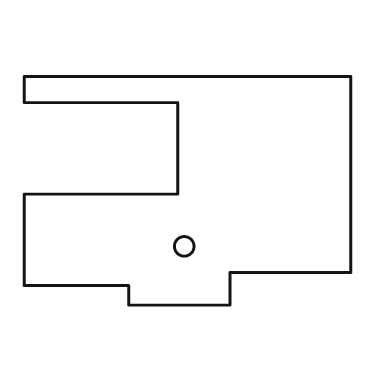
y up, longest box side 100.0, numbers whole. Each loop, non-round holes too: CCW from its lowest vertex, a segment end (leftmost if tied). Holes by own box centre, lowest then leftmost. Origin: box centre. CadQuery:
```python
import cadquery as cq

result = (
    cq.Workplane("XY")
    .moveTo(-18.0, -35.0)
    .lineTo(13.0, -35.0)
    .lineTo(13.0, -25.0)
    .lineTo(50.0, -25.0)
    .lineTo(50.0, 35.0)
    .lineTo(-50.0, 35.0)
    .lineTo(-50.0, 27.0)
    .lineTo(-3.0, 27.0)
    .lineTo(-3.0, -1.0)
    .lineTo(-50.0, -1.0)
    .lineTo(-50.0, -29.0)
    .lineTo(-18.0, -29.0)
    .close()
    .moveTo(-1.0, -17.0)
    .circle(3.0)
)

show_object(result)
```